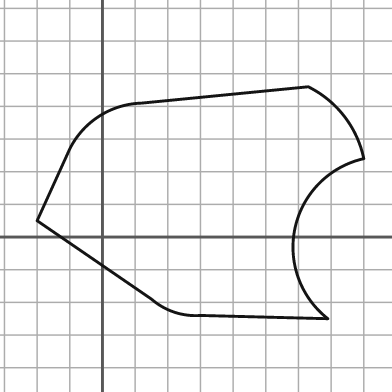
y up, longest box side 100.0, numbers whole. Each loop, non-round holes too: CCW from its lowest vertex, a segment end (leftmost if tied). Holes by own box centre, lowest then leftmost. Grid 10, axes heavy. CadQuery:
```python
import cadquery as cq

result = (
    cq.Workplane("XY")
    .moveTo(69.0, -25.0)
    .threePointArc((59.0, 3.0), (80.0, 24.0))
    .threePointArc((74.0, 37.0), (63.0, 46.0))
    .lineTo(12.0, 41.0)
    .threePointArc((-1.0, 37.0), (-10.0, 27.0))
    .lineTo(-20.0, 5.0)
    .lineTo(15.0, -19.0)
    .threePointArc((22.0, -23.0), (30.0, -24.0))
    .close()
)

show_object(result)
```